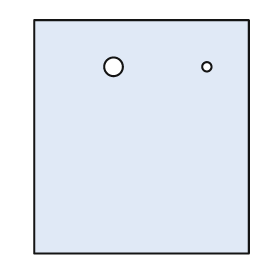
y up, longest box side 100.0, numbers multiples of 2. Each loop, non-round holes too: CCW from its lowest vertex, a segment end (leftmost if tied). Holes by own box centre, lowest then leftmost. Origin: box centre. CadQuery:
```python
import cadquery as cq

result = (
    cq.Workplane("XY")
    .moveTo(-46.0, -50.0)
    .lineTo(46.0, -50.0)
    .lineTo(46.0, 50.0)
    .lineTo(-46.0, 50.0)
    .close()
    .moveTo(-12.0, 30.0)
    .circle(4.0)
    .moveTo(28.0, 30.0)
    .circle(2.0)
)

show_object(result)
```